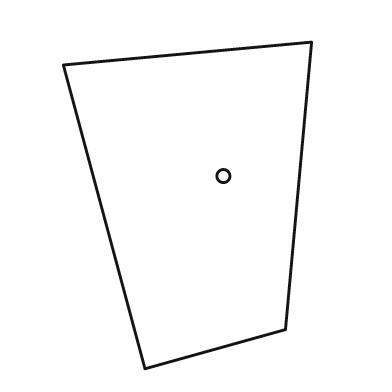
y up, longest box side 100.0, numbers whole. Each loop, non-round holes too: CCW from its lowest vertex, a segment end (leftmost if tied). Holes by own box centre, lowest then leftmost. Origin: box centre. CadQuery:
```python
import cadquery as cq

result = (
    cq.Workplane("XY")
    .moveTo(-13.0, -50.0)
    .lineTo(30.0, -38.0)
    .lineTo(38.0, 50.0)
    .lineTo(-38.0, 43.0)
    .close()
    .moveTo(11.0, 9.0)
    .circle(2.0)
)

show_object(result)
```